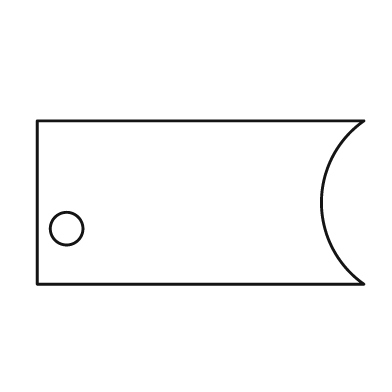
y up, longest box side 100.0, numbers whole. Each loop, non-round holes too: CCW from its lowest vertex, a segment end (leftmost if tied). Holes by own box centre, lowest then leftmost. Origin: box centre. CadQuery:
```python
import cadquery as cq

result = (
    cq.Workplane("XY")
    .moveTo(-50.0, -25.0)
    .lineTo(50.0, -25.0)
    .threePointArc((37.0, 0.0), (50.0, 25.0))
    .lineTo(-50.0, 25.0)
    .close()
    .moveTo(-41.0, -8.0)
    .circle(5.0)
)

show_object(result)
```